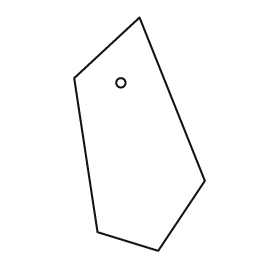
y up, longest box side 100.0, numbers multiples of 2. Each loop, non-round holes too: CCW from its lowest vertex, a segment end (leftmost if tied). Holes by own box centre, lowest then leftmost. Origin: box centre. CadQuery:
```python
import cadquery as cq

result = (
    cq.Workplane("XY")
    .moveTo(8.0, -50.0)
    .lineTo(28.0, -20.0)
    .lineTo(0.0, 50.0)
    .lineTo(-28.0, 24.0)
    .lineTo(-18.0, -42.0)
    .close()
    .moveTo(-8.0, 22.0)
    .circle(2.0)
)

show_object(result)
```